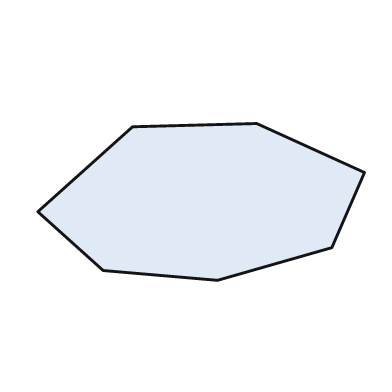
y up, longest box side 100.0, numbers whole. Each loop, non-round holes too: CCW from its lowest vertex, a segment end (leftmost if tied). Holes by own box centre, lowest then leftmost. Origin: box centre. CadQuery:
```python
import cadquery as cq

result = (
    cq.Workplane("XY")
    .moveTo(5.0, -24.0)
    .lineTo(40.0, -14.0)
    .lineTo(50.0, 9.0)
    .lineTo(17.0, 24.0)
    .lineTo(-21.0, 23.0)
    .lineTo(-50.0, -3.0)
    .lineTo(-30.0, -21.0)
    .close()
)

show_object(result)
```